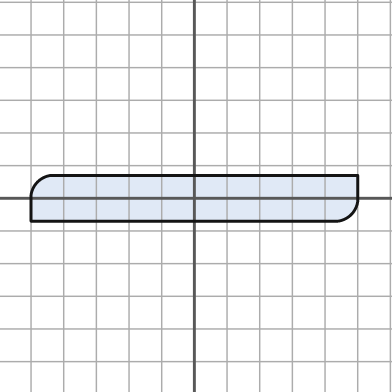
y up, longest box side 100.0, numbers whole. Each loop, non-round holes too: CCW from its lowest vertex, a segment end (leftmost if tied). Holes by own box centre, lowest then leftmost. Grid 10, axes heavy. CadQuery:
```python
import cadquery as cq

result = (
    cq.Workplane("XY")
    .moveTo(-50.0, -7.0)
    .lineTo(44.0, -7.0)
    .threePointArc((48.0, -5.0), (50.0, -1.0))
    .lineTo(50.0, 7.0)
    .lineTo(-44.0, 7.0)
    .threePointArc((-48.0, 5.0), (-50.0, 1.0))
    .close()
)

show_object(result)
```